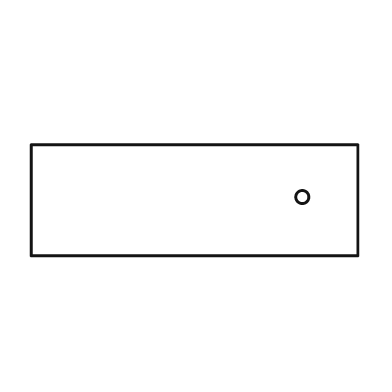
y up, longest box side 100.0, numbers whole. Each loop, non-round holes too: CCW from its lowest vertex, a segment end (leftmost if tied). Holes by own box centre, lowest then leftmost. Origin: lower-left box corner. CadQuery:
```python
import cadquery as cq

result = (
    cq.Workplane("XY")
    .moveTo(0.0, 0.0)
    .lineTo(100.0, 0.0)
    .lineTo(100.0, 34.0)
    .lineTo(0.0, 34.0)
    .close()
    .moveTo(83.0, 18.0)
    .circle(2.0)
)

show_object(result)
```